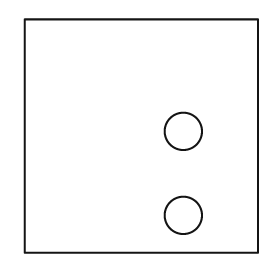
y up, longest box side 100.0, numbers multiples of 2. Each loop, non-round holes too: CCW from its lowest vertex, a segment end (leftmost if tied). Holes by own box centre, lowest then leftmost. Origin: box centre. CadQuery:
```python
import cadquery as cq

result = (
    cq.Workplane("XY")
    .moveTo(-50.0, -50.0)
    .lineTo(50.0, -50.0)
    .lineTo(50.0, 50.0)
    .lineTo(-50.0, 50.0)
    .close()
    .moveTo(18.0, -34.0)
    .circle(8.0)
    .moveTo(18.0, 2.0)
    .circle(8.0)
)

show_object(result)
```